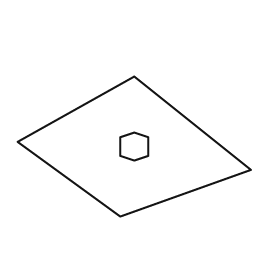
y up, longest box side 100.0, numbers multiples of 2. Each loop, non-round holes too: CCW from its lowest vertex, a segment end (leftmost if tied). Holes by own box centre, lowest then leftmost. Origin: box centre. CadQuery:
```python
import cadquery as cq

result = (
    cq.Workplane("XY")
    .moveTo(-6.0, -30.0)
    .lineTo(50.0, -10.0)
    .lineTo(0.0, 30.0)
    .lineTo(-50.0, 2.0)
    .close()
    .moveTo(0.0, -6.0)
    .lineTo(6.0, -4.0)
    .lineTo(6.0, 4.0)
    .lineTo(0.0, 6.0)
    .lineTo(-6.0, 4.0)
    .lineTo(-6.0, -4.0)
    .close()
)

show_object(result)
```